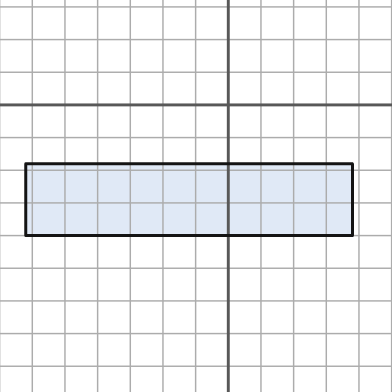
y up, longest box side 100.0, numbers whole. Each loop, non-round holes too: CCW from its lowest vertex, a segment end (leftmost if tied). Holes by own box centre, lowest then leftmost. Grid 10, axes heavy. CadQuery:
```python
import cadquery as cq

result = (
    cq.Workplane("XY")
    .moveTo(-62.0, -40.0)
    .lineTo(38.0, -40.0)
    .lineTo(38.0, -18.0)
    .lineTo(-62.0, -18.0)
    .close()
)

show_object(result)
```